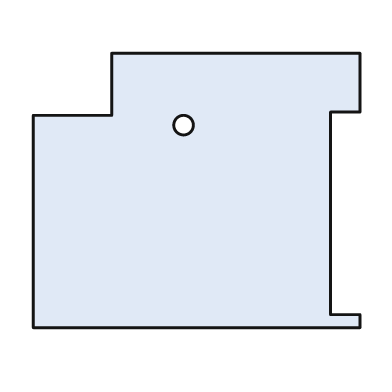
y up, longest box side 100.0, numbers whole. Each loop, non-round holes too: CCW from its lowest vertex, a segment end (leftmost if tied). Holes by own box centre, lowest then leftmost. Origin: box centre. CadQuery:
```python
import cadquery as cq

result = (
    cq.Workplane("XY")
    .moveTo(-50.0, -42.0)
    .lineTo(50.0, -42.0)
    .lineTo(50.0, -38.0)
    .lineTo(41.0, -38.0)
    .lineTo(41.0, 24.0)
    .lineTo(50.0, 24.0)
    .lineTo(50.0, 42.0)
    .lineTo(-26.0, 42.0)
    .lineTo(-26.0, 23.0)
    .lineTo(-50.0, 23.0)
    .close()
    .moveTo(-4.0, 20.0)
    .circle(3.0)
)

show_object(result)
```